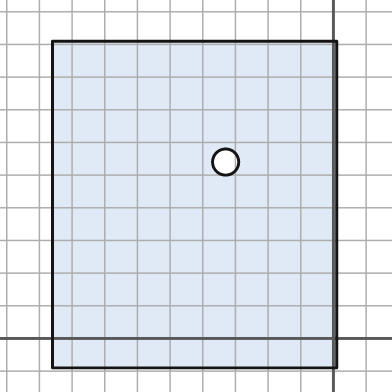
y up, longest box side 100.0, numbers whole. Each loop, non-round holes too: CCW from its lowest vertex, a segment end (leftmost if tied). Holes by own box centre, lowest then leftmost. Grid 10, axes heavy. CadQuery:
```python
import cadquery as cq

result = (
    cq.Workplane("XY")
    .moveTo(-86.0, -9.0)
    .lineTo(1.0, -9.0)
    .lineTo(1.0, 91.0)
    .lineTo(-86.0, 91.0)
    .close()
    .moveTo(-33.0, 54.0)
    .circle(4.0)
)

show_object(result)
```